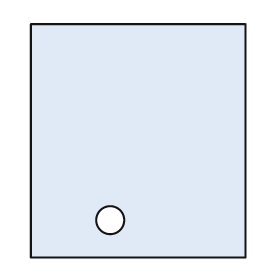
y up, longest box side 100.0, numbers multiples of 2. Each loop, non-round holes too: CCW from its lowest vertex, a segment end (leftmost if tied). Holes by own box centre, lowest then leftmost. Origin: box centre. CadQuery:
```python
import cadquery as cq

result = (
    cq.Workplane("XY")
    .moveTo(-46.0, -50.0)
    .lineTo(46.0, -50.0)
    .lineTo(46.0, 50.0)
    .lineTo(-46.0, 50.0)
    .close()
    .moveTo(-12.0, -34.0)
    .circle(6.0)
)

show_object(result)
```